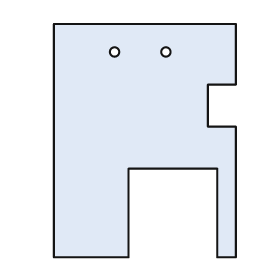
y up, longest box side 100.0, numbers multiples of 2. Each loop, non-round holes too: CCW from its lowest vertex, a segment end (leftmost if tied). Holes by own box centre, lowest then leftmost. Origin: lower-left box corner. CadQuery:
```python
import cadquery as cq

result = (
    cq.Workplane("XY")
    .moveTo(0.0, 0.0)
    .lineTo(32.0, 0.0)
    .lineTo(32.0, 38.0)
    .lineTo(70.0, 38.0)
    .lineTo(70.0, 0.0)
    .lineTo(78.0, 0.0)
    .lineTo(78.0, 56.0)
    .lineTo(66.0, 56.0)
    .lineTo(66.0, 74.0)
    .lineTo(78.0, 74.0)
    .lineTo(78.0, 100.0)
    .lineTo(0.0, 100.0)
    .close()
    .moveTo(26.0, 88.0)
    .circle(2.0)
    .moveTo(48.0, 88.0)
    .circle(2.0)
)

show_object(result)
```